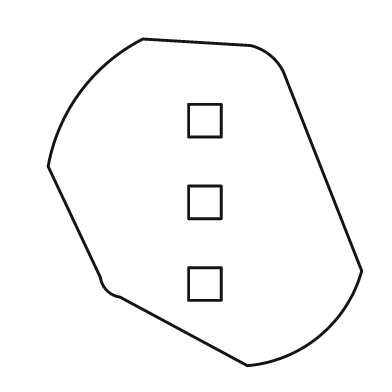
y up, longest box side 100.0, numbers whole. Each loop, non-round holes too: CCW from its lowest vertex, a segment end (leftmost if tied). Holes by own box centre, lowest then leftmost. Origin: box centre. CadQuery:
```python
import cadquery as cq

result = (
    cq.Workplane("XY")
    .moveTo(13.0, -50.0)
    .threePointArc((35.0, -41.0), (48.0, -21.0))
    .lineTo(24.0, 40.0)
    .threePointArc((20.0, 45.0), (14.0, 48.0))
    .lineTo(-19.0, 50.0)
    .threePointArc((-38.0, 34.0), (-48.0, 11.0))
    .lineTo(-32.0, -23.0)
    .threePointArc((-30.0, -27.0), (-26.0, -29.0))
    .close()
    .moveTo(-5.0, -30.0)
    .lineTo(5.0, -30.0)
    .lineTo(5.0, -20.0)
    .lineTo(-5.0, -20.0)
    .close()
    .moveTo(-5.0, -5.0)
    .lineTo(5.0, -5.0)
    .lineTo(5.0, 5.0)
    .lineTo(-5.0, 5.0)
    .close()
    .moveTo(-5.0, 20.0)
    .lineTo(5.0, 20.0)
    .lineTo(5.0, 30.0)
    .lineTo(-5.0, 30.0)
    .close()
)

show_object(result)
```